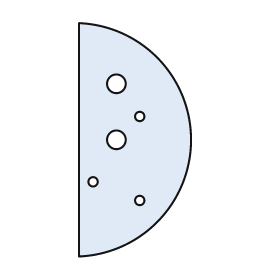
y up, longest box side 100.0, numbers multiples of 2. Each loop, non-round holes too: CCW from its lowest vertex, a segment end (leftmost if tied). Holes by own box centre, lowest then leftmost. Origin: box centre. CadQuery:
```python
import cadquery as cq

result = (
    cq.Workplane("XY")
    .moveTo(-24.0, -50.0)
    .threePointArc((24.0, 0.0), (-24.0, 50.0))
    .close()
    .moveTo(2.0, -26.0)
    .circle(2.0)
    .moveTo(-18.0, -18.0)
    .circle(2.0)
    .moveTo(-8.0, 0.0)
    .circle(4.0)
    .moveTo(2.0, 10.0)
    .circle(2.0)
    .moveTo(-8.0, 24.0)
    .circle(4.0)
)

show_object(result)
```